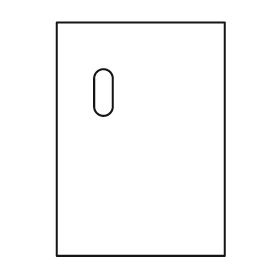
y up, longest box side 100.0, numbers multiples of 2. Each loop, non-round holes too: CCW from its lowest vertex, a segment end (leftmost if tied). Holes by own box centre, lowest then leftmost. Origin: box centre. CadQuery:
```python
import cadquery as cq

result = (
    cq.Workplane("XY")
    .moveTo(-36.0, -50.0)
    .lineTo(36.0, -50.0)
    .lineTo(36.0, 50.0)
    .lineTo(-36.0, 50.0)
    .close()
    .moveTo(-20.0, 14.0)
    .threePointArc((-16.0, 10.0), (-12.0, 14.0))
    .lineTo(-12.0, 26.0)
    .threePointArc((-16.0, 30.0), (-20.0, 26.0))
    .close()
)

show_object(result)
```